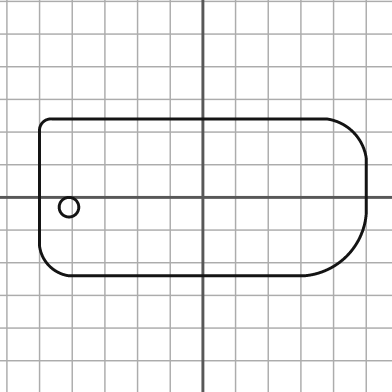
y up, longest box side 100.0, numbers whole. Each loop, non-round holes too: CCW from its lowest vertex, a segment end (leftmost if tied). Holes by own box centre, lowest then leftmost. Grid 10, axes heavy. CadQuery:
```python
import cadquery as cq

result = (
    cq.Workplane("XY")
    .moveTo(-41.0, -24.0)
    .lineTo(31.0, -24.0)
    .threePointArc((44.0, -18.0), (50.0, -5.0))
    .lineTo(50.0, 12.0)
    .threePointArc((46.0, 20.0), (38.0, 24.0))
    .lineTo(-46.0, 24.0)
    .threePointArc((-49.0, 23.0), (-50.0, 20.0))
    .lineTo(-50.0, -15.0)
    .threePointArc((-47.0, -21.0), (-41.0, -24.0))
    .close()
    .moveTo(-41.0, -3.0)
    .circle(3.0)
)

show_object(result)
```